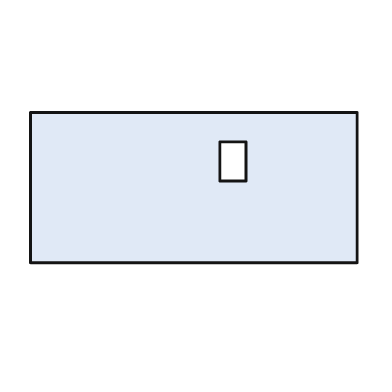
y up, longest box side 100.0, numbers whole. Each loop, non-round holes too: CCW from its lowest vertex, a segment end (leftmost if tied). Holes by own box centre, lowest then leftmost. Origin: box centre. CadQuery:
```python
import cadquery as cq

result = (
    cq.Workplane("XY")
    .moveTo(-50.0, -23.0)
    .lineTo(50.0, -23.0)
    .lineTo(50.0, 23.0)
    .lineTo(-50.0, 23.0)
    .close()
    .moveTo(8.0, 2.0)
    .lineTo(16.0, 2.0)
    .lineTo(16.0, 14.0)
    .lineTo(8.0, 14.0)
    .close()
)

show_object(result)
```